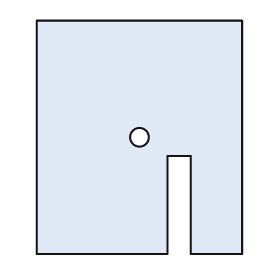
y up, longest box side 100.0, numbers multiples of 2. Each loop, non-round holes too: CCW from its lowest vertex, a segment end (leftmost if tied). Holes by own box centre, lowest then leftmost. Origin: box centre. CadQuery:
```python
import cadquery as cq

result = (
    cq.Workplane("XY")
    .moveTo(-44.0, -50.0)
    .lineTo(12.0, -50.0)
    .lineTo(12.0, -8.0)
    .lineTo(22.0, -8.0)
    .lineTo(22.0, -50.0)
    .lineTo(44.0, -50.0)
    .lineTo(44.0, 50.0)
    .lineTo(-44.0, 50.0)
    .close()
    .moveTo(0.0, 0.0)
    .circle(4.0)
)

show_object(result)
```